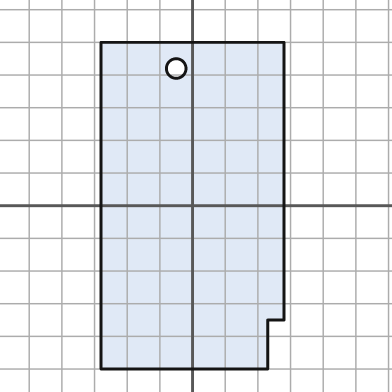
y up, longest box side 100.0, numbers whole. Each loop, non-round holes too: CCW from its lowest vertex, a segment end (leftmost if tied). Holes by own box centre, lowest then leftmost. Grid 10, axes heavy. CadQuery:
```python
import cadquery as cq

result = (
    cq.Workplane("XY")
    .moveTo(-28.0, -50.0)
    .lineTo(23.0, -50.0)
    .lineTo(23.0, -35.0)
    .lineTo(28.0, -35.0)
    .lineTo(28.0, 50.0)
    .lineTo(-28.0, 50.0)
    .close()
    .moveTo(-5.0, 42.0)
    .circle(3.0)
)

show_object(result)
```